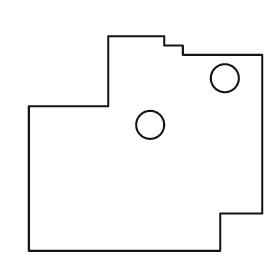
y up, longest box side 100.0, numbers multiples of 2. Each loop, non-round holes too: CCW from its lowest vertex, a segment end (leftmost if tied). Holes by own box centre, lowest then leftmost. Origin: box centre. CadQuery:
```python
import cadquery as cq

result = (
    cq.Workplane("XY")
    .moveTo(-50.0, -46.0)
    .lineTo(32.0, -46.0)
    .lineTo(32.0, -30.0)
    .lineTo(50.0, -30.0)
    .lineTo(50.0, 38.0)
    .lineTo(16.0, 38.0)
    .lineTo(16.0, 42.0)
    .lineTo(8.0, 42.0)
    .lineTo(8.0, 46.0)
    .lineTo(-16.0, 46.0)
    .lineTo(-16.0, 16.0)
    .lineTo(-50.0, 16.0)
    .close()
    .moveTo(2.0, 8.0)
    .circle(6.0)
    .moveTo(34.0, 28.0)
    .circle(6.0)
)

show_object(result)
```